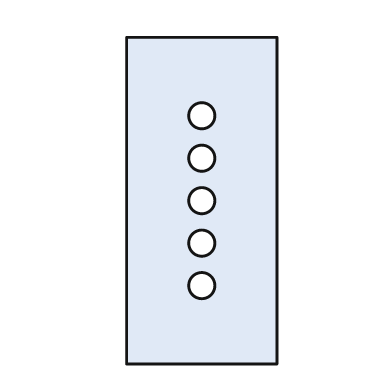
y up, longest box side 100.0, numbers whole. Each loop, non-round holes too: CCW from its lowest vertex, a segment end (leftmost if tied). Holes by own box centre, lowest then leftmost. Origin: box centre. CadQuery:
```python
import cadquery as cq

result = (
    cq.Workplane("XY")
    .moveTo(-23.0, -50.0)
    .lineTo(23.0, -50.0)
    .lineTo(23.0, 50.0)
    .lineTo(-23.0, 50.0)
    .close()
    .moveTo(0.0, -26.0)
    .circle(4.0)
    .moveTo(0.0, -13.0)
    .circle(4.0)
    .moveTo(0.0, 0.0)
    .circle(4.0)
    .moveTo(0.0, 13.0)
    .circle(4.0)
    .moveTo(0.0, 26.0)
    .circle(4.0)
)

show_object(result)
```